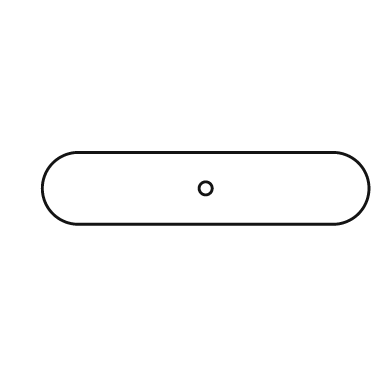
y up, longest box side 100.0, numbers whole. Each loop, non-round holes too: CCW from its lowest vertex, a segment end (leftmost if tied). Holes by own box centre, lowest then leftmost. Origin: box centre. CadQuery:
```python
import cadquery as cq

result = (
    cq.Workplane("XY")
    .moveTo(-39.0, -11.0)
    .lineTo(39.0, -11.0)
    .threePointArc((50.0, 0.0), (39.0, 11.0))
    .lineTo(-39.0, 11.0)
    .threePointArc((-50.0, 0.0), (-39.0, -11.0))
    .close()
    .moveTo(0.0, 0.0)
    .circle(2.0)
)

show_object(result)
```